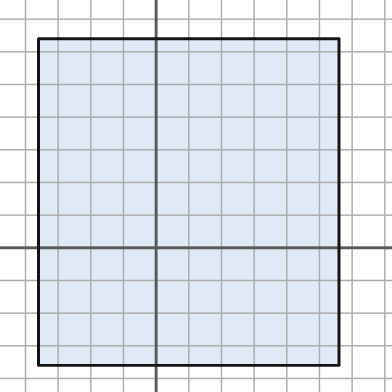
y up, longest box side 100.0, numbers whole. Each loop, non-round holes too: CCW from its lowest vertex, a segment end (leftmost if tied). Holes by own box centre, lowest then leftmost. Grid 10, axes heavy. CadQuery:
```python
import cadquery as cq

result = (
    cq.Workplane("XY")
    .moveTo(-36.0, -36.0)
    .lineTo(56.0, -36.0)
    .lineTo(56.0, 64.0)
    .lineTo(-36.0, 64.0)
    .close()
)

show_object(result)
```